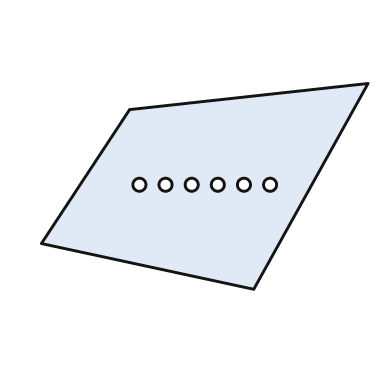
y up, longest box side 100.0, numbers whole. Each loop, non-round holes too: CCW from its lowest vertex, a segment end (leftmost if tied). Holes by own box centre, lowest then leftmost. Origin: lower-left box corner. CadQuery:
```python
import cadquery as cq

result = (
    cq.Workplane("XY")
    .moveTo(65.0, 0.0)
    .lineTo(100.0, 63.0)
    .lineTo(27.0, 55.0)
    .lineTo(0.0, 14.0)
    .close()
    .moveTo(30.0, 32.0)
    .circle(2.0)
    .moveTo(38.0, 32.0)
    .circle(2.0)
    .moveTo(46.0, 32.0)
    .circle(2.0)
    .moveTo(54.0, 32.0)
    .circle(2.0)
    .moveTo(62.0, 32.0)
    .circle(2.0)
    .moveTo(70.0, 32.0)
    .circle(2.0)
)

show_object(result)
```